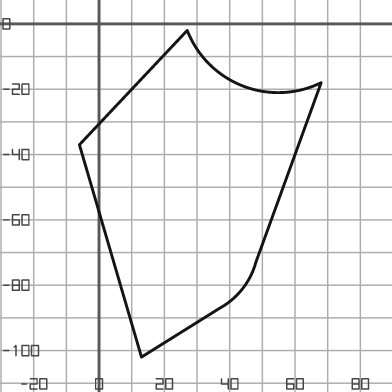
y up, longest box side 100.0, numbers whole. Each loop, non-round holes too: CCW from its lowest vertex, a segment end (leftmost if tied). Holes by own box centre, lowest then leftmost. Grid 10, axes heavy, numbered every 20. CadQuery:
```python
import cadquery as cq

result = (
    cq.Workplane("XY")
    .moveTo(13.0, -102.0)
    .lineTo(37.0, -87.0)
    .threePointArc((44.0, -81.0), (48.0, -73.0))
    .lineTo(68.0, -18.0)
    .threePointArc((44.0, -19.0), (27.0, -2.0))
    .lineTo(-6.0, -37.0)
    .close()
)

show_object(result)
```